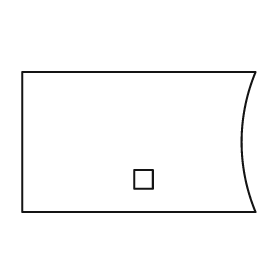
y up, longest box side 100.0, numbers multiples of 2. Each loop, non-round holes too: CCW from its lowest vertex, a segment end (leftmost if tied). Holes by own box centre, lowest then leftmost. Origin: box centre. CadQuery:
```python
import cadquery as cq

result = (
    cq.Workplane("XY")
    .moveTo(-50.0, -30.0)
    .lineTo(50.0, -30.0)
    .threePointArc((44.0, 0.0), (50.0, 30.0))
    .lineTo(-50.0, 30.0)
    .close()
    .moveTo(-2.0, -20.0)
    .lineTo(6.0, -20.0)
    .lineTo(6.0, -12.0)
    .lineTo(-2.0, -12.0)
    .close()
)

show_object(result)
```